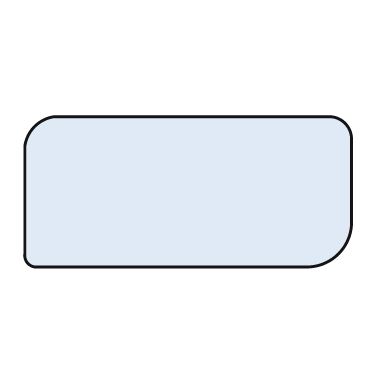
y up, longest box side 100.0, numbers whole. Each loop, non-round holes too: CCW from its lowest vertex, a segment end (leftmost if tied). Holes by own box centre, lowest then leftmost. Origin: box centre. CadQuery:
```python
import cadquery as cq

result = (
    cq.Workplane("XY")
    .moveTo(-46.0, -23.0)
    .lineTo(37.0, -23.0)
    .threePointArc((46.0, -19.0), (50.0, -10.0))
    .lineTo(50.0, 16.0)
    .threePointArc((48.0, 21.0), (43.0, 23.0))
    .lineTo(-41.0, 23.0)
    .threePointArc((-47.0, 20.0), (-50.0, 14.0))
    .lineTo(-50.0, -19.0)
    .threePointArc((-49.0, -22.0), (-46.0, -23.0))
    .close()
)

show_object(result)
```